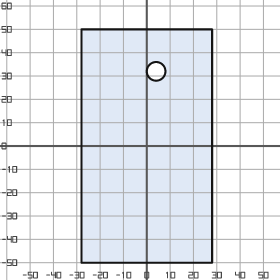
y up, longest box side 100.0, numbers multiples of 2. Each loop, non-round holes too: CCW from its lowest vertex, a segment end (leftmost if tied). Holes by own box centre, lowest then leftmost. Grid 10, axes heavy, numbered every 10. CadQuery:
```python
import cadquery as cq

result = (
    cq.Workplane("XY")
    .moveTo(-28.0, -50.0)
    .lineTo(28.0, -50.0)
    .lineTo(28.0, 50.0)
    .lineTo(-28.0, 50.0)
    .close()
    .moveTo(4.0, 32.0)
    .circle(4.0)
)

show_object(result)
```